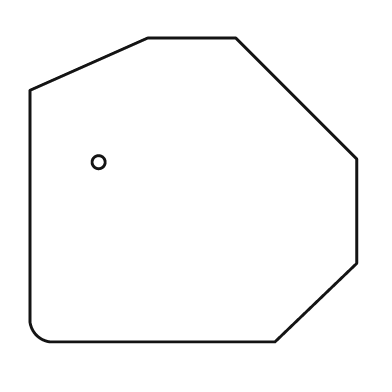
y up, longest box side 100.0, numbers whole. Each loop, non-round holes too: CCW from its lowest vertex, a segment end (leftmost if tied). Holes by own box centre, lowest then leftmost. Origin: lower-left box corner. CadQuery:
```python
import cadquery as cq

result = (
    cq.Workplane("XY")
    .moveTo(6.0, 0.0)
    .lineTo(75.0, 0.0)
    .lineTo(100.0, 24.0)
    .lineTo(100.0, 56.0)
    .lineTo(63.0, 93.0)
    .lineTo(36.0, 93.0)
    .lineTo(0.0, 77.0)
    .lineTo(0.0, 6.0)
    .threePointArc((2.0, 2.0), (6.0, 0.0))
    .close()
    .moveTo(21.0, 55.0)
    .circle(2.0)
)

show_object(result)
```